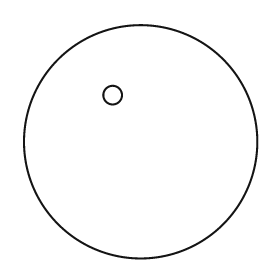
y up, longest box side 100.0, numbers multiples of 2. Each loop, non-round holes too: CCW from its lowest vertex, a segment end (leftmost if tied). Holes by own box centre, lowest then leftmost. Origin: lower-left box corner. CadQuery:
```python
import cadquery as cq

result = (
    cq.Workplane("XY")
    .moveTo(50.0, 50.0)
    .circle(50.0)
    .moveTo(38.0, 70.0)
    .circle(4.0)
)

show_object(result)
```